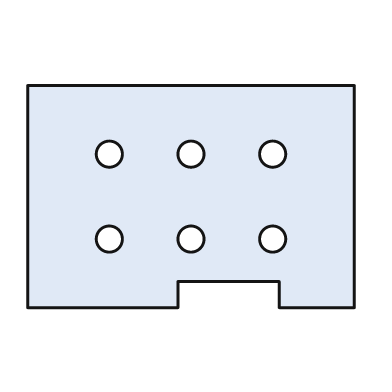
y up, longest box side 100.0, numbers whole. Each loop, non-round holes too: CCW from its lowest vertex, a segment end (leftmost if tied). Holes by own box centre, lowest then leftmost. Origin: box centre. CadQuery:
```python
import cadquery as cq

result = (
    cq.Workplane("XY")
    .moveTo(-50.0, -34.0)
    .lineTo(-4.0, -34.0)
    .lineTo(-4.0, -26.0)
    .lineTo(27.0, -26.0)
    .lineTo(27.0, -34.0)
    .lineTo(50.0, -34.0)
    .lineTo(50.0, 34.0)
    .lineTo(-50.0, 34.0)
    .close()
    .moveTo(-25.0, -13.0)
    .circle(4.0)
    .moveTo(0.0, -13.0)
    .circle(4.0)
    .moveTo(25.0, -13.0)
    .circle(4.0)
    .moveTo(-25.0, 13.0)
    .circle(4.0)
    .moveTo(0.0, 13.0)
    .circle(4.0)
    .moveTo(25.0, 13.0)
    .circle(4.0)
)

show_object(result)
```